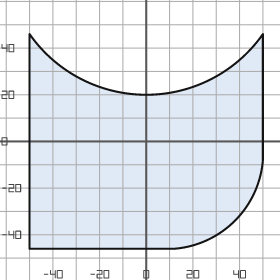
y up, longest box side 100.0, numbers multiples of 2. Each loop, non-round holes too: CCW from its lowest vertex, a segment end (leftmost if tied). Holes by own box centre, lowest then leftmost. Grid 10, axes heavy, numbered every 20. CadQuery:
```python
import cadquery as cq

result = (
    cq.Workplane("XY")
    .moveTo(-50.0, -46.0)
    .lineTo(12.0, -46.0)
    .threePointArc((38.0, -34.0), (50.0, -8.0))
    .lineTo(50.0, 46.0)
    .threePointArc((0.0, 20.0), (-50.0, 46.0))
    .close()
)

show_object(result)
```